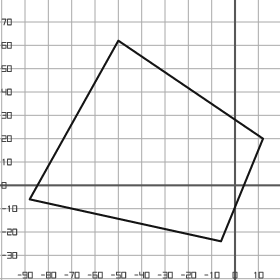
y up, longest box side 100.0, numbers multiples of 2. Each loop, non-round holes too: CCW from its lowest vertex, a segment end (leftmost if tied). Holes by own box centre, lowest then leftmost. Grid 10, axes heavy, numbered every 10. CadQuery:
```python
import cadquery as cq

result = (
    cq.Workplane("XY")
    .moveTo(-6.0, -24.0)
    .lineTo(12.0, 20.0)
    .lineTo(-50.0, 62.0)
    .lineTo(-88.0, -6.0)
    .close()
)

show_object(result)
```